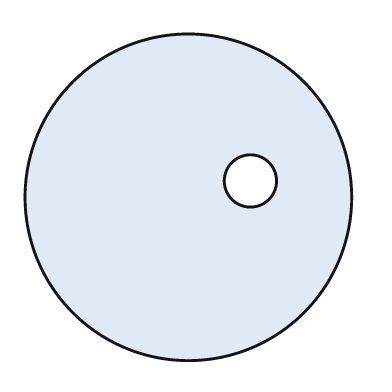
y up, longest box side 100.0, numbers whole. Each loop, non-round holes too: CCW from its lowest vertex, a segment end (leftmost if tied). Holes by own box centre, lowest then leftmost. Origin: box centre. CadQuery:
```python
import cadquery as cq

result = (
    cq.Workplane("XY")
    .moveTo(0.0, 0.0)
    .circle(50.0)
    .moveTo(19.0, 5.0)
    .circle(8.0)
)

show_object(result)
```